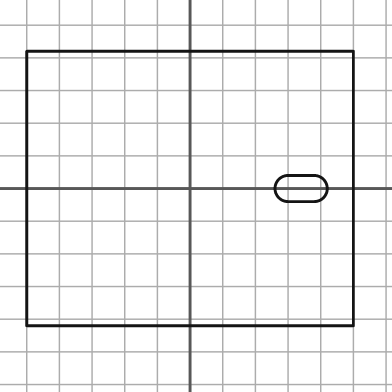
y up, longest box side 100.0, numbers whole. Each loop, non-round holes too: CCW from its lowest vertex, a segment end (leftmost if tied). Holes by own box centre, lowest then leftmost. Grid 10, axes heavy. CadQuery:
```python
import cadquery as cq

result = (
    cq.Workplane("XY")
    .moveTo(-50.0, -42.0)
    .lineTo(50.0, -42.0)
    .lineTo(50.0, 42.0)
    .lineTo(-50.0, 42.0)
    .close()
    .moveTo(30.0, -4.0)
    .lineTo(38.0, -4.0)
    .threePointArc((42.0, 0.0), (38.0, 4.0))
    .lineTo(30.0, 4.0)
    .threePointArc((26.0, 0.0), (30.0, -4.0))
    .close()
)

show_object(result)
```